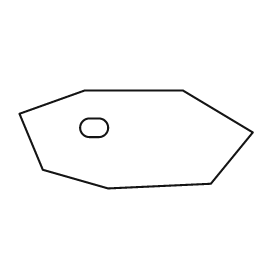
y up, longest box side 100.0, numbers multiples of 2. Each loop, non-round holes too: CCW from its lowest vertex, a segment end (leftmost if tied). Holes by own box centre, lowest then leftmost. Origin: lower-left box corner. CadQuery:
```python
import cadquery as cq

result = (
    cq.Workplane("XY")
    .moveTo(38.0, 0.0)
    .lineTo(82.0, 2.0)
    .lineTo(100.0, 24.0)
    .lineTo(70.0, 42.0)
    .lineTo(28.0, 42.0)
    .lineTo(0.0, 32.0)
    .lineTo(10.0, 8.0)
    .close()
    .moveTo(30.0, 22.0)
    .lineTo(34.0, 22.0)
    .threePointArc((38.0, 26.0), (34.0, 30.0))
    .lineTo(30.0, 30.0)
    .threePointArc((26.0, 26.0), (30.0, 22.0))
    .close()
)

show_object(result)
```